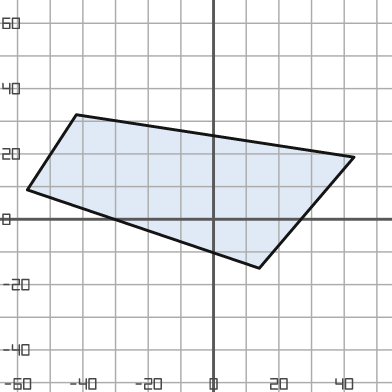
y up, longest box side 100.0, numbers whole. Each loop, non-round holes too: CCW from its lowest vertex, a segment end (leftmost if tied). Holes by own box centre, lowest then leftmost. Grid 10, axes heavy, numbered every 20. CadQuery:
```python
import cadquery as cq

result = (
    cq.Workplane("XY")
    .moveTo(14.0, -15.0)
    .lineTo(43.0, 19.0)
    .lineTo(-42.0, 32.0)
    .lineTo(-57.0, 9.0)
    .close()
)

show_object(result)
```